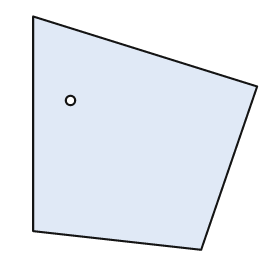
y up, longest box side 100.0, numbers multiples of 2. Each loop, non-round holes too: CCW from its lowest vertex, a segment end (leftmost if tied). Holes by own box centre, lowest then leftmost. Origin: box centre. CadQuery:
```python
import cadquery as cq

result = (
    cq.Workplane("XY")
    .moveTo(24.0, -50.0)
    .lineTo(48.0, 20.0)
    .lineTo(-48.0, 50.0)
    .lineTo(-48.0, -42.0)
    .close()
    .moveTo(-32.0, 14.0)
    .circle(2.0)
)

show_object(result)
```